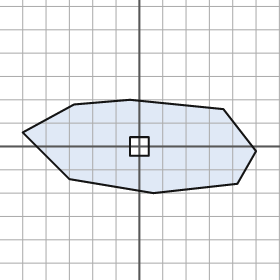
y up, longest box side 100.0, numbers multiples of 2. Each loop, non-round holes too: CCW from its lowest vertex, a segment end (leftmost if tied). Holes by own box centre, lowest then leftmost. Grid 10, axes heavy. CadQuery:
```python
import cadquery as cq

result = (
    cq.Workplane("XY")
    .moveTo(6.0, -20.0)
    .lineTo(42.0, -16.0)
    .lineTo(50.0, -2.0)
    .lineTo(36.0, 16.0)
    .lineTo(-4.0, 20.0)
    .lineTo(-28.0, 18.0)
    .lineTo(-50.0, 6.0)
    .lineTo(-30.0, -14.0)
    .close()
    .moveTo(-4.0, -4.0)
    .lineTo(4.0, -4.0)
    .lineTo(4.0, 4.0)
    .lineTo(-4.0, 4.0)
    .close()
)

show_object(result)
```